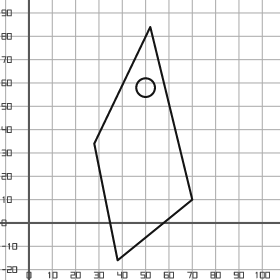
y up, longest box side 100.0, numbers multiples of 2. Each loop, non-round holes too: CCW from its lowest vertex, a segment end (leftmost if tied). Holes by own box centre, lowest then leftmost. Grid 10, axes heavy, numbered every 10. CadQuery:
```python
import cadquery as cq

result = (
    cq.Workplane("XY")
    .moveTo(38.0, -16.0)
    .lineTo(70.0, 10.0)
    .lineTo(52.0, 84.0)
    .lineTo(28.0, 34.0)
    .close()
    .moveTo(50.0, 58.0)
    .circle(4.0)
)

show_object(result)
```